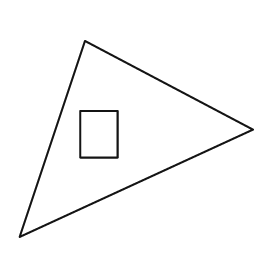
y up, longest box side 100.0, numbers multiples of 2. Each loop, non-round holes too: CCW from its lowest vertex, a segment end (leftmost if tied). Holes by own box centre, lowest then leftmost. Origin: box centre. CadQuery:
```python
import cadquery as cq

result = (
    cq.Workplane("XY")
    .moveTo(-50.0, -42.0)
    .lineTo(50.0, 4.0)
    .lineTo(-22.0, 42.0)
    .close()
    .moveTo(-24.0, -8.0)
    .lineTo(-8.0, -8.0)
    .lineTo(-8.0, 12.0)
    .lineTo(-24.0, 12.0)
    .close()
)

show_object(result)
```